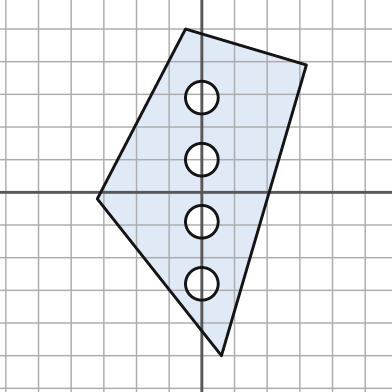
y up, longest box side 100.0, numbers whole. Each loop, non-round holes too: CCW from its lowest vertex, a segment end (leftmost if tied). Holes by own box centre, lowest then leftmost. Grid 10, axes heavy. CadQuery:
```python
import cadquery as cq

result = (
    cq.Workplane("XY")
    .moveTo(6.0, -50.0)
    .lineTo(32.0, 39.0)
    .lineTo(-5.0, 50.0)
    .lineTo(-32.0, -2.0)
    .close()
    .moveTo(0.0, -28.0)
    .circle(5.0)
    .moveTo(0.0, -9.0)
    .circle(5.0)
    .moveTo(0.0, 10.0)
    .circle(5.0)
    .moveTo(0.0, 29.0)
    .circle(5.0)
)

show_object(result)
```